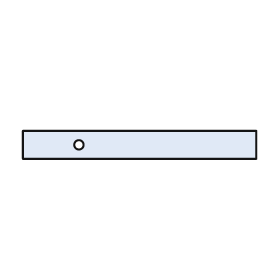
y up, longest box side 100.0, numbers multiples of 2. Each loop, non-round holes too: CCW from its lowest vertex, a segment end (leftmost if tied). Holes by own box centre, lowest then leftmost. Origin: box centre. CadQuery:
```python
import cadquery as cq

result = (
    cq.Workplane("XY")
    .moveTo(-50.0, -6.0)
    .lineTo(50.0, -6.0)
    .lineTo(50.0, 6.0)
    .lineTo(-50.0, 6.0)
    .close()
    .moveTo(-26.0, 0.0)
    .circle(2.0)
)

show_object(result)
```